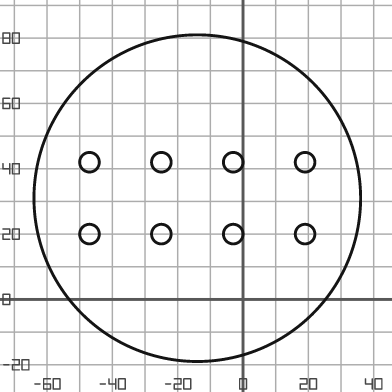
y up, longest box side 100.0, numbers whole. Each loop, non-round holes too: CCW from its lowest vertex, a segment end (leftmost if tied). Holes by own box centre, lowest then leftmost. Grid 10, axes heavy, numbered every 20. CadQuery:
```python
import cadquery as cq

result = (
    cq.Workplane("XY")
    .moveTo(-14.0, 31.0)
    .circle(50.0)
    .moveTo(-47.0, 20.0)
    .circle(3.0)
    .moveTo(-25.0, 20.0)
    .circle(3.0)
    .moveTo(-3.0, 20.0)
    .circle(3.0)
    .moveTo(19.0, 20.0)
    .circle(3.0)
    .moveTo(-47.0, 42.0)
    .circle(3.0)
    .moveTo(-25.0, 42.0)
    .circle(3.0)
    .moveTo(-3.0, 42.0)
    .circle(3.0)
    .moveTo(19.0, 42.0)
    .circle(3.0)
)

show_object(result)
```